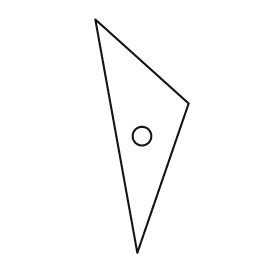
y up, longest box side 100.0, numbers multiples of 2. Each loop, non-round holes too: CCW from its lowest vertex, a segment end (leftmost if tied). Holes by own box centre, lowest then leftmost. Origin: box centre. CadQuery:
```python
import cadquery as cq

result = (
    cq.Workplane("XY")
    .moveTo(-2.0, -50.0)
    .lineTo(20.0, 14.0)
    .lineTo(-20.0, 50.0)
    .close()
    .moveTo(0.0, 0.0)
    .circle(4.0)
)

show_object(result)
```